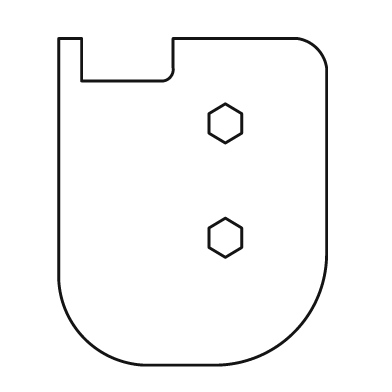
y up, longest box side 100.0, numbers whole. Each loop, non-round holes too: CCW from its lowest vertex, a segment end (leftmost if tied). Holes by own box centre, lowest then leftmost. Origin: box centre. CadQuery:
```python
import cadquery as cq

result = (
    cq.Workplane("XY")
    .moveTo(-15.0, -50.0)
    .lineTo(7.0, -50.0)
    .threePointArc((31.0, -40.0), (41.0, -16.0))
    .lineTo(41.0, 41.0)
    .threePointArc((38.0, 47.0), (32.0, 50.0))
    .lineTo(-6.0, 50.0)
    .lineTo(-6.0, 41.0)
    .threePointArc((-7.0, 38.0), (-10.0, 37.0))
    .lineTo(-34.0, 37.0)
    .lineTo(-34.0, 50.0)
    .lineTo(-41.0, 50.0)
    .lineTo(-41.0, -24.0)
    .threePointArc((-33.0, -42.0), (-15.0, -50.0))
    .close()
    .moveTo(10.0, -17.0)
    .lineTo(15.0, -14.0)
    .lineTo(15.0, -8.0)
    .lineTo(10.0, -5.0)
    .lineTo(5.0, -8.0)
    .lineTo(5.0, -14.0)
    .close()
    .moveTo(10.0, 18.0)
    .lineTo(15.0, 21.0)
    .lineTo(15.0, 27.0)
    .lineTo(10.0, 30.0)
    .lineTo(5.0, 27.0)
    .lineTo(5.0, 21.0)
    .close()
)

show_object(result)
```